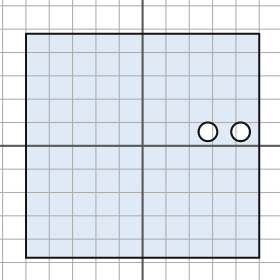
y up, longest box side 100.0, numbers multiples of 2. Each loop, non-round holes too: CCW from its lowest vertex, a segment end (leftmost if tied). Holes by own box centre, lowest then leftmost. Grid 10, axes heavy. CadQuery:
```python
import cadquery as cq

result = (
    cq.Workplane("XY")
    .moveTo(-50.0, -48.0)
    .lineTo(50.0, -48.0)
    .lineTo(50.0, 48.0)
    .lineTo(-50.0, 48.0)
    .close()
    .moveTo(28.0, 6.0)
    .circle(4.0)
    .moveTo(42.0, 6.0)
    .circle(4.0)
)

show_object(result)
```